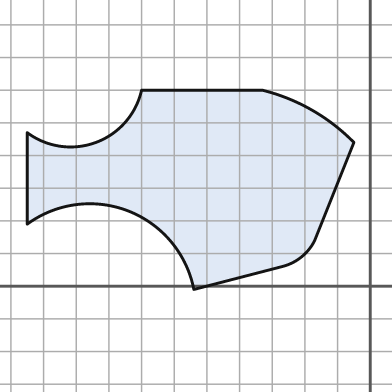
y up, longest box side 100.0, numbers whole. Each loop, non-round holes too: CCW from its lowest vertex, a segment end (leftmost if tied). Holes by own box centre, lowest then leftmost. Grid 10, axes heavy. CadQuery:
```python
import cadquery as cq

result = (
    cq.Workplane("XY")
    .moveTo(-54.0, -1.0)
    .lineTo(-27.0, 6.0)
    .threePointArc((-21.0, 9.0), (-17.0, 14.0))
    .lineTo(-5.0, 44.0)
    .threePointArc((-18.0, 54.0), (-33.0, 60.0))
    .lineTo(-70.0, 60.0)
    .threePointArc((-84.0, 44.0), (-105.0, 47.0))
    .lineTo(-105.0, 19.0)
    .threePointArc((-74.0, 23.0), (-54.0, -1.0))
    .close()
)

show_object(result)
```